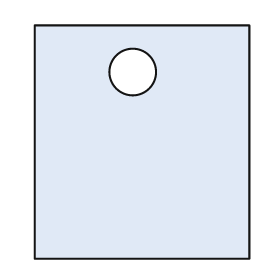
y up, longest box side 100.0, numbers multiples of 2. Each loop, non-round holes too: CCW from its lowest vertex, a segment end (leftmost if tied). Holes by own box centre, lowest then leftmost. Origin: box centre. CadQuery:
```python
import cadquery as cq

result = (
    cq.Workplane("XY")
    .moveTo(-46.0, -50.0)
    .lineTo(46.0, -50.0)
    .lineTo(46.0, 50.0)
    .lineTo(-46.0, 50.0)
    .close()
    .moveTo(-4.0, 30.0)
    .circle(10.0)
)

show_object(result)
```